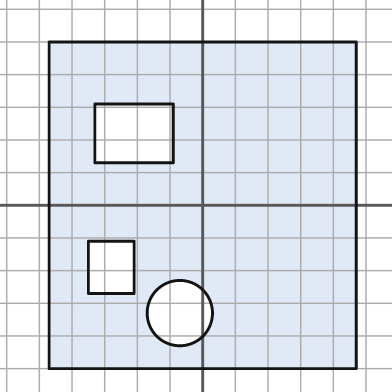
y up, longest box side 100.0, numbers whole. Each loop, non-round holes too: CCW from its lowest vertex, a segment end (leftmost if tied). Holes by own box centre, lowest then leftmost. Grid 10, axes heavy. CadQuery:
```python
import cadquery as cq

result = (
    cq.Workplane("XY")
    .moveTo(-47.0, -50.0)
    .lineTo(47.0, -50.0)
    .lineTo(47.0, 50.0)
    .lineTo(-47.0, 50.0)
    .close()
    .moveTo(-7.0, -33.0)
    .circle(10.0)
    .moveTo(-35.0, -27.0)
    .lineTo(-21.0, -27.0)
    .lineTo(-21.0, -11.0)
    .lineTo(-35.0, -11.0)
    .close()
    .moveTo(-33.0, 13.0)
    .lineTo(-9.0, 13.0)
    .lineTo(-9.0, 31.0)
    .lineTo(-33.0, 31.0)
    .close()
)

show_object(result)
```